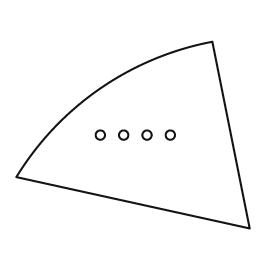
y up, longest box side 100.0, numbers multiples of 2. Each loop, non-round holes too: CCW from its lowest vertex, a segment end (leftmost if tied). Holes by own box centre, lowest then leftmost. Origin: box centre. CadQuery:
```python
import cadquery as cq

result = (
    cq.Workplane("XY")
    .moveTo(50.0, -40.0)
    .lineTo(34.0, 40.0)
    .threePointArc((-14.0, 20.0), (-50.0, -18.0))
    .close()
    .moveTo(-14.0, 0.0)
    .circle(2.0)
    .moveTo(-4.0, 0.0)
    .circle(2.0)
    .moveTo(6.0, 0.0)
    .circle(2.0)
    .moveTo(16.0, 0.0)
    .circle(2.0)
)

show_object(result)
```